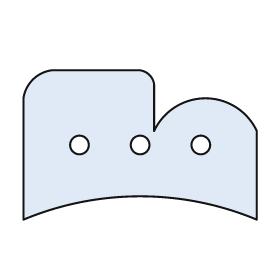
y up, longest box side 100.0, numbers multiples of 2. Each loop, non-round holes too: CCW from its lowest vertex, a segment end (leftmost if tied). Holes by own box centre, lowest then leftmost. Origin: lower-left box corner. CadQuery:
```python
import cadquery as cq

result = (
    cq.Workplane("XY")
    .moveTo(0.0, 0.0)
    .threePointArc((50.0, 10.0), (100.0, 0.0))
    .lineTo(100.0, 38.0)
    .threePointArc((78.0, 52.0), (56.0, 38.0))
    .lineTo(56.0, 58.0)
    .threePointArc((54.0, 62.0), (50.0, 64.0))
    .lineTo(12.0, 64.0)
    .threePointArc((4.0, 60.0), (0.0, 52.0))
    .close()
    .moveTo(24.0, 32.0)
    .circle(4.0)
    .moveTo(50.0, 32.0)
    .circle(4.0)
    .moveTo(76.0, 32.0)
    .circle(4.0)
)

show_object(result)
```